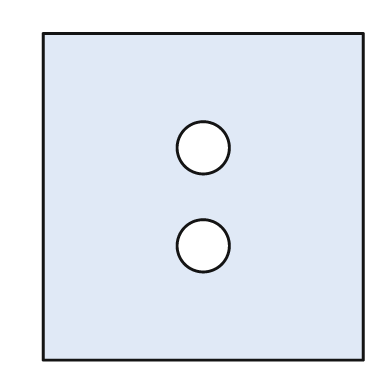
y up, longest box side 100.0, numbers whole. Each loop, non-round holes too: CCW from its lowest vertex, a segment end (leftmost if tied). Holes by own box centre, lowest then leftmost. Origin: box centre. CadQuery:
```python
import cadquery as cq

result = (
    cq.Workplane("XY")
    .moveTo(-49.0, -50.0)
    .lineTo(49.0, -50.0)
    .lineTo(49.0, 50.0)
    .lineTo(-49.0, 50.0)
    .close()
    .moveTo(0.0, -15.0)
    .circle(8.0)
    .moveTo(0.0, 15.0)
    .circle(8.0)
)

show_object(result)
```